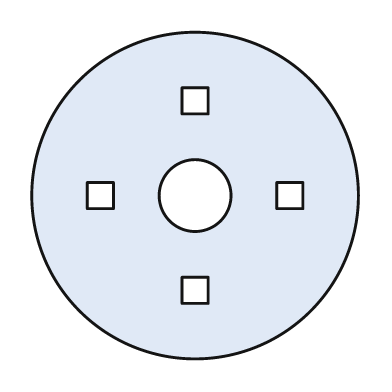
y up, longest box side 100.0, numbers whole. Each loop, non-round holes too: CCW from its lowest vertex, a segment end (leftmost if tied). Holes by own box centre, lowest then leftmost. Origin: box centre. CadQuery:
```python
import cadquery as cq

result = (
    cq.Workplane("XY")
    .moveTo(0.0, 0.0)
    .circle(50.0)
    .moveTo(-4.0, -33.0)
    .lineTo(4.0, -33.0)
    .lineTo(4.0, -25.0)
    .lineTo(-4.0, -25.0)
    .close()
    .moveTo(-33.0, -4.0)
    .lineTo(-25.0, -4.0)
    .lineTo(-25.0, 4.0)
    .lineTo(-33.0, 4.0)
    .close()
    .moveTo(0.0, 0.0)
    .circle(11.0)
    .moveTo(25.0, -4.0)
    .lineTo(33.0, -4.0)
    .lineTo(33.0, 4.0)
    .lineTo(25.0, 4.0)
    .close()
    .moveTo(-4.0, 25.0)
    .lineTo(4.0, 25.0)
    .lineTo(4.0, 33.0)
    .lineTo(-4.0, 33.0)
    .close()
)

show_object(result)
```